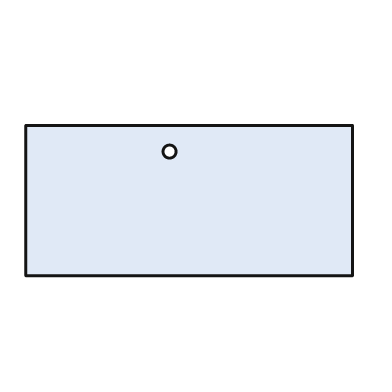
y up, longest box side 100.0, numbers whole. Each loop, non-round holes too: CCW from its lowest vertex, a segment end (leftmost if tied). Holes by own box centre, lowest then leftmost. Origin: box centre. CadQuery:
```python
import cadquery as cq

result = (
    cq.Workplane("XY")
    .moveTo(-50.0, -23.0)
    .lineTo(50.0, -23.0)
    .lineTo(50.0, 23.0)
    .lineTo(-50.0, 23.0)
    .close()
    .moveTo(-6.0, 15.0)
    .circle(2.0)
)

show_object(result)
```